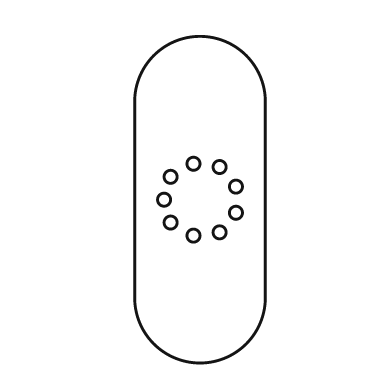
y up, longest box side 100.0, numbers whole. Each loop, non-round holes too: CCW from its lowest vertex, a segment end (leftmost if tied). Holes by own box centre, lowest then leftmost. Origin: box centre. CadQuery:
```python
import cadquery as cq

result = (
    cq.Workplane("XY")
    .moveTo(-20.0, -30.0)
    .threePointArc((0.0, -50.0), (20.0, -30.0))
    .lineTo(20.0, 30.0)
    .threePointArc((0.0, 50.0), (-20.0, 30.0))
    .close()
    .moveTo(-2.0, -11.0)
    .circle(2.0)
    .moveTo(6.0, -10.0)
    .circle(2.0)
    .moveTo(-9.0, -7.0)
    .circle(2.0)
    .moveTo(11.0, -4.0)
    .circle(2.0)
    .moveTo(-11.0, 0.0)
    .circle(2.0)
    .moveTo(11.0, 4.0)
    .circle(2.0)
    .moveTo(-9.0, 7.0)
    .circle(2.0)
    .moveTo(6.0, 10.0)
    .circle(2.0)
    .moveTo(-2.0, 11.0)
    .circle(2.0)
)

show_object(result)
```